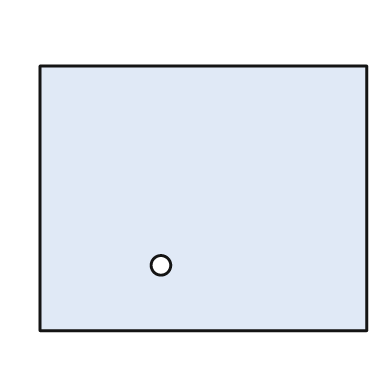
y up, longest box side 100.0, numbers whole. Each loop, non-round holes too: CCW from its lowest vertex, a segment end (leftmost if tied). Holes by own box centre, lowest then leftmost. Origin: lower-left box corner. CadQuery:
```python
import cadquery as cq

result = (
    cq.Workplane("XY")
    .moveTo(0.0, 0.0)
    .lineTo(100.0, 0.0)
    .lineTo(100.0, 81.0)
    .lineTo(0.0, 81.0)
    .close()
    .moveTo(37.0, 20.0)
    .circle(3.0)
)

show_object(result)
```